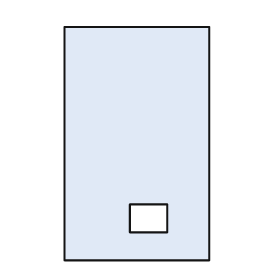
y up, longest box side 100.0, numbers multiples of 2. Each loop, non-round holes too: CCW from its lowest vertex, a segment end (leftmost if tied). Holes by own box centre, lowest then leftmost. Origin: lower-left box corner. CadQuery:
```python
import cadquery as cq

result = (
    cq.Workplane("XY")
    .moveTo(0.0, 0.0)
    .lineTo(62.0, 0.0)
    .lineTo(62.0, 100.0)
    .lineTo(0.0, 100.0)
    .close()
    .moveTo(28.0, 12.0)
    .lineTo(44.0, 12.0)
    .lineTo(44.0, 24.0)
    .lineTo(28.0, 24.0)
    .close()
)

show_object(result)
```